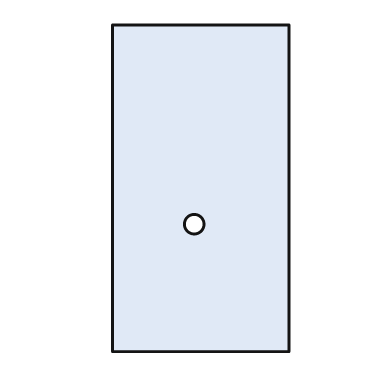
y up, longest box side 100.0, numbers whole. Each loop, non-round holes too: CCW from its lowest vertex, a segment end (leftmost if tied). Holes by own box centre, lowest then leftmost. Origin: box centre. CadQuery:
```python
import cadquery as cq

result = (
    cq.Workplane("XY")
    .moveTo(-27.0, -50.0)
    .lineTo(27.0, -50.0)
    .lineTo(27.0, 50.0)
    .lineTo(-27.0, 50.0)
    .close()
    .moveTo(-2.0, -11.0)
    .circle(3.0)
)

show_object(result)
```